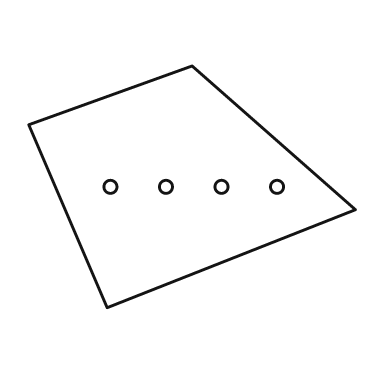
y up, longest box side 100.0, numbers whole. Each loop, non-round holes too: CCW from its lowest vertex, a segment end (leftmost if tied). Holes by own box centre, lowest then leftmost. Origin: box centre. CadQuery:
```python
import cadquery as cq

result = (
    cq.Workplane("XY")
    .moveTo(-26.0, -37.0)
    .lineTo(50.0, -7.0)
    .lineTo(0.0, 37.0)
    .lineTo(-50.0, 19.0)
    .close()
    .moveTo(-25.0, 0.0)
    .circle(2.0)
    .moveTo(-8.0, 0.0)
    .circle(2.0)
    .moveTo(9.0, 0.0)
    .circle(2.0)
    .moveTo(26.0, 0.0)
    .circle(2.0)
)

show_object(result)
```